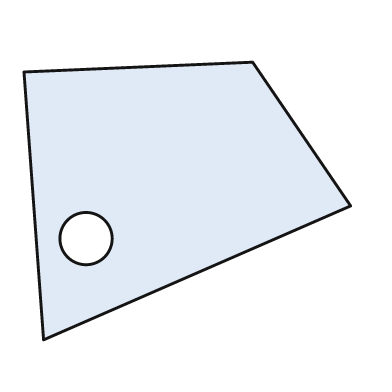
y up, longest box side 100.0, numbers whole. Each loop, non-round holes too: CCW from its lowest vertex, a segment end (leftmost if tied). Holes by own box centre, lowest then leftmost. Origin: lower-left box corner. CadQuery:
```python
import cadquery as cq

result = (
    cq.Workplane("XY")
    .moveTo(6.0, 0.0)
    .lineTo(100.0, 41.0)
    .lineTo(70.0, 85.0)
    .lineTo(0.0, 82.0)
    .close()
    .moveTo(19.0, 31.0)
    .circle(8.0)
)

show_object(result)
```